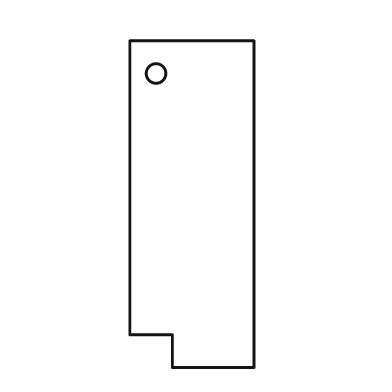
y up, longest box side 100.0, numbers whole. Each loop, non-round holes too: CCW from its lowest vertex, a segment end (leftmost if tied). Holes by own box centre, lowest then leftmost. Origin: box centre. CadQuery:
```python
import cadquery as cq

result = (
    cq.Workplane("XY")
    .moveTo(-6.0, -50.0)
    .lineTo(19.0, -50.0)
    .lineTo(19.0, 50.0)
    .lineTo(-19.0, 50.0)
    .lineTo(-19.0, -40.0)
    .lineTo(-6.0, -40.0)
    .close()
    .moveTo(-11.0, 40.0)
    .circle(3.0)
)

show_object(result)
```